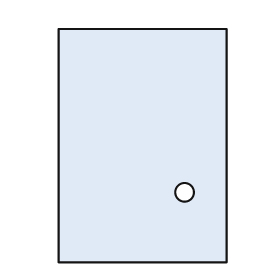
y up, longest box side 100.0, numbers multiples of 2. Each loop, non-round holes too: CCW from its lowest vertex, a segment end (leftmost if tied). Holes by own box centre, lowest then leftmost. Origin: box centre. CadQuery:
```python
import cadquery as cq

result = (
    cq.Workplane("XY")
    .moveTo(-36.0, -50.0)
    .lineTo(36.0, -50.0)
    .lineTo(36.0, 50.0)
    .lineTo(-36.0, 50.0)
    .close()
    .moveTo(18.0, -20.0)
    .circle(4.0)
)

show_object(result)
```